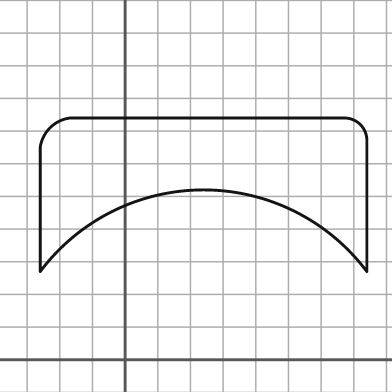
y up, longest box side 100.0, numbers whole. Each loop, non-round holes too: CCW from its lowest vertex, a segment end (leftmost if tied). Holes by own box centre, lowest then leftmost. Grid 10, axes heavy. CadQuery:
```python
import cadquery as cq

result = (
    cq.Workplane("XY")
    .moveTo(-26.0, 27.0)
    .threePointArc((24.0, 52.0), (74.0, 27.0))
    .lineTo(74.0, 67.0)
    .threePointArc((72.0, 72.0), (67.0, 74.0))
    .lineTo(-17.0, 74.0)
    .threePointArc((-23.0, 71.0), (-26.0, 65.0))
    .close()
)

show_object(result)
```